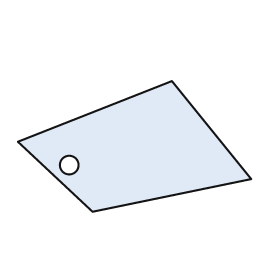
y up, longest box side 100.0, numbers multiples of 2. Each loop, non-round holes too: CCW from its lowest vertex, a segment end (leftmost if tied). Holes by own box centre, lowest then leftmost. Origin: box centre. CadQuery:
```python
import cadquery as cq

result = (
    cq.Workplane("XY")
    .moveTo(-18.0, -28.0)
    .lineTo(50.0, -14.0)
    .lineTo(16.0, 28.0)
    .lineTo(-50.0, 2.0)
    .close()
    .moveTo(-28.0, -8.0)
    .circle(4.0)
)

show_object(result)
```